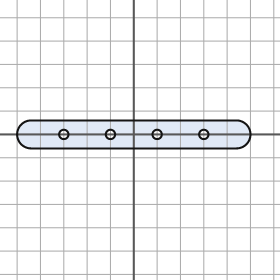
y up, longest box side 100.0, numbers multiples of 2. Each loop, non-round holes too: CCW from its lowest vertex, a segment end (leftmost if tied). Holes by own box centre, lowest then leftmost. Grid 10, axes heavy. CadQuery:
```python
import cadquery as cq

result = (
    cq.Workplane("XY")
    .moveTo(-44.0, -6.0)
    .lineTo(44.0, -6.0)
    .threePointArc((50.0, 0.0), (44.0, 6.0))
    .lineTo(-44.0, 6.0)
    .threePointArc((-50.0, 0.0), (-44.0, -6.0))
    .close()
    .moveTo(-30.0, 0.0)
    .circle(2.0)
    .moveTo(-10.0, 0.0)
    .circle(2.0)
    .moveTo(10.0, 0.0)
    .circle(2.0)
    .moveTo(30.0, 0.0)
    .circle(2.0)
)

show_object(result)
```